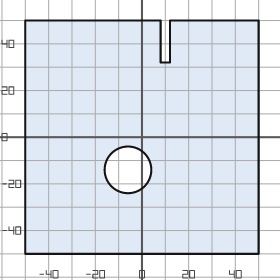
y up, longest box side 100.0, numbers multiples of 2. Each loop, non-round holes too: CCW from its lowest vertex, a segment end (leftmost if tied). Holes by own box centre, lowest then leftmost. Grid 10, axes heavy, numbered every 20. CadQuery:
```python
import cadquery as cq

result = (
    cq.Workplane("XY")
    .moveTo(-50.0, -50.0)
    .lineTo(50.0, -50.0)
    .lineTo(50.0, 50.0)
    .lineTo(12.0, 50.0)
    .lineTo(12.0, 32.0)
    .lineTo(8.0, 32.0)
    .lineTo(8.0, 50.0)
    .lineTo(-50.0, 50.0)
    .close()
    .moveTo(-6.0, -14.0)
    .circle(10.0)
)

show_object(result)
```